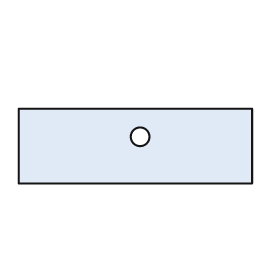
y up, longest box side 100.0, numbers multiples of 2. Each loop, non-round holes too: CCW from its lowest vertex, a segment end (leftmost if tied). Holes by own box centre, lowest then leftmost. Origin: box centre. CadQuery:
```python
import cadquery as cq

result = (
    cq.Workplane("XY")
    .moveTo(-50.0, -16.0)
    .lineTo(50.0, -16.0)
    .lineTo(50.0, 16.0)
    .lineTo(-50.0, 16.0)
    .close()
    .moveTo(2.0, 4.0)
    .circle(4.0)
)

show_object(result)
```